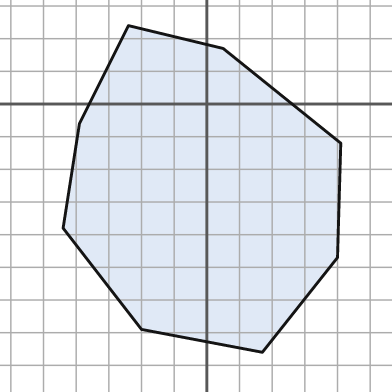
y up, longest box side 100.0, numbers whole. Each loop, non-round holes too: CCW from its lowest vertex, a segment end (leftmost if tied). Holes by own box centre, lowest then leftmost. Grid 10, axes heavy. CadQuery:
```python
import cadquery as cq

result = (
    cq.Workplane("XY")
    .moveTo(17.0, -76.0)
    .lineTo(40.0, -47.0)
    .lineTo(41.0, -12.0)
    .lineTo(5.0, 17.0)
    .lineTo(-24.0, 24.0)
    .lineTo(-39.0, -6.0)
    .lineTo(-44.0, -38.0)
    .lineTo(-20.0, -69.0)
    .close()
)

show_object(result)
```